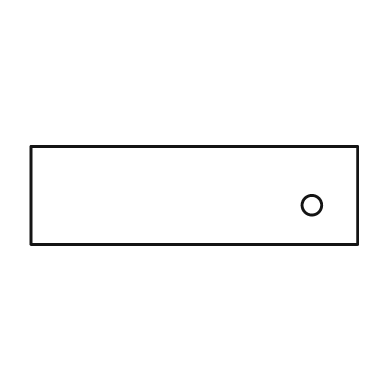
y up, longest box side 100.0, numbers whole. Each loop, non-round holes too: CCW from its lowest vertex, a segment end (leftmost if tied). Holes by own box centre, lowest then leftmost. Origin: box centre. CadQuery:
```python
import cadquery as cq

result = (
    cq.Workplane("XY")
    .moveTo(-50.0, -15.0)
    .lineTo(50.0, -15.0)
    .lineTo(50.0, 15.0)
    .lineTo(-50.0, 15.0)
    .close()
    .moveTo(36.0, -3.0)
    .circle(3.0)
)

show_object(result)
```